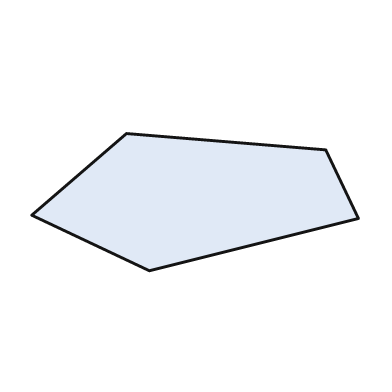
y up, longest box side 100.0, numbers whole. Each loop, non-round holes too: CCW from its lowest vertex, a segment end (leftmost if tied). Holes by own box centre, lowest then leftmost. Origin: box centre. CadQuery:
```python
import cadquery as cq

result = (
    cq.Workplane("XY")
    .moveTo(-14.0, -21.0)
    .lineTo(50.0, -5.0)
    .lineTo(40.0, 16.0)
    .lineTo(-21.0, 21.0)
    .lineTo(-50.0, -4.0)
    .close()
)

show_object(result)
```